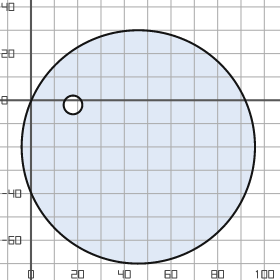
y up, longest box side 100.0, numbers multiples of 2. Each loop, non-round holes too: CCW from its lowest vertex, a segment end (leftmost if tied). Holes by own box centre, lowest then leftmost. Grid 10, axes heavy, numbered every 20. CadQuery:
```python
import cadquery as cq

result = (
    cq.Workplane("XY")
    .moveTo(46.0, -20.0)
    .circle(50.0)
    .moveTo(18.0, -2.0)
    .circle(4.0)
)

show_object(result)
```